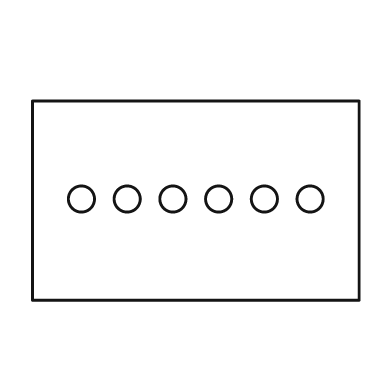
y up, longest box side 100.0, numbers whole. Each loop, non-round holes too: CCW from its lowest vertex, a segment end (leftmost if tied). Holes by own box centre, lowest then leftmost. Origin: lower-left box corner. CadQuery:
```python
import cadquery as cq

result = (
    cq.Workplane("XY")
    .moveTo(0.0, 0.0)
    .lineTo(100.0, 0.0)
    .lineTo(100.0, 61.0)
    .lineTo(0.0, 61.0)
    .close()
    .moveTo(15.0, 31.0)
    .circle(4.0)
    .moveTo(29.0, 31.0)
    .circle(4.0)
    .moveTo(43.0, 31.0)
    .circle(4.0)
    .moveTo(57.0, 31.0)
    .circle(4.0)
    .moveTo(71.0, 31.0)
    .circle(4.0)
    .moveTo(85.0, 31.0)
    .circle(4.0)
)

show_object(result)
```